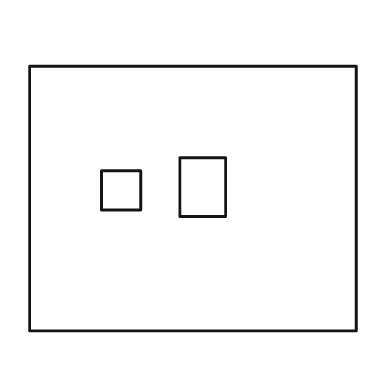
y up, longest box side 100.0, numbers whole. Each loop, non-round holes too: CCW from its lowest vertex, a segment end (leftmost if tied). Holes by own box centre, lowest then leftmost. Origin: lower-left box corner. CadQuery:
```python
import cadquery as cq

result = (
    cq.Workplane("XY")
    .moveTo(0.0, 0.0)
    .lineTo(100.0, 0.0)
    .lineTo(100.0, 81.0)
    .lineTo(0.0, 81.0)
    .close()
    .moveTo(22.0, 37.0)
    .lineTo(34.0, 37.0)
    .lineTo(34.0, 49.0)
    .lineTo(22.0, 49.0)
    .close()
    .moveTo(46.0, 35.0)
    .lineTo(60.0, 35.0)
    .lineTo(60.0, 53.0)
    .lineTo(46.0, 53.0)
    .close()
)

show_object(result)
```